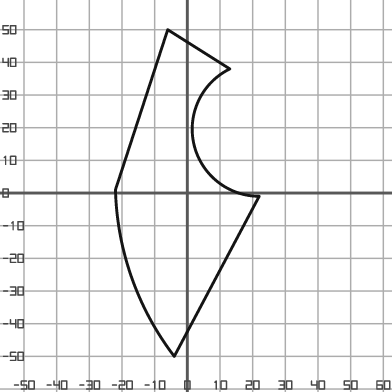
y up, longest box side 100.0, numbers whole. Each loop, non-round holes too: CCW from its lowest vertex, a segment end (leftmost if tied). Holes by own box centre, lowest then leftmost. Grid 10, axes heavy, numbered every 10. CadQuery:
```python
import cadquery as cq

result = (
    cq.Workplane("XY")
    .moveTo(-4.0, -50.0)
    .lineTo(22.0, -1.0)
    .threePointArc((2.0, 15.0), (13.0, 38.0))
    .lineTo(-6.0, 50.0)
    .lineTo(-22.0, 1.0)
    .threePointArc((-17.0, -26.0), (-4.0, -50.0))
    .close()
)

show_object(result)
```